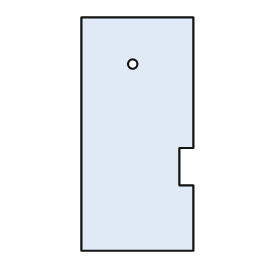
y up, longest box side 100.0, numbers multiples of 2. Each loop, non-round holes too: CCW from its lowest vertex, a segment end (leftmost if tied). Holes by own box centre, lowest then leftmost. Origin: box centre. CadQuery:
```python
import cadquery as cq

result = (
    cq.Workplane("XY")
    .moveTo(-24.0, -50.0)
    .lineTo(24.0, -50.0)
    .lineTo(24.0, -22.0)
    .lineTo(18.0, -22.0)
    .lineTo(18.0, -6.0)
    .lineTo(24.0, -6.0)
    .lineTo(24.0, 50.0)
    .lineTo(-24.0, 50.0)
    .close()
    .moveTo(-2.0, 30.0)
    .circle(2.0)
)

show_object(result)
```